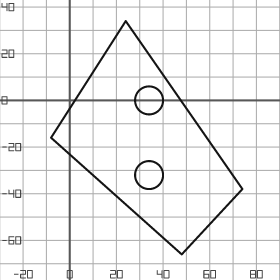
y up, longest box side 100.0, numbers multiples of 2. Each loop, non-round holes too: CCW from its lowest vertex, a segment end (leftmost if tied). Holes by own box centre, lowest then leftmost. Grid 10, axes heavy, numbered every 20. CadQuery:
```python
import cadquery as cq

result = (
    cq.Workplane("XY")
    .moveTo(48.0, -66.0)
    .lineTo(74.0, -38.0)
    .lineTo(24.0, 34.0)
    .lineTo(-8.0, -16.0)
    .close()
    .moveTo(34.0, -32.0)
    .circle(6.0)
    .moveTo(34.0, 0.0)
    .circle(6.0)
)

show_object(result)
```